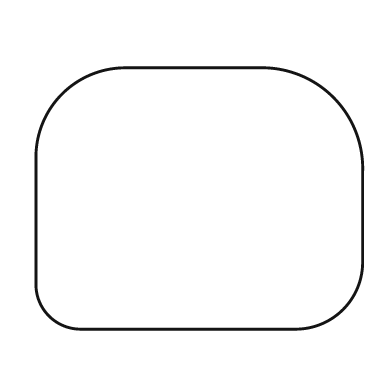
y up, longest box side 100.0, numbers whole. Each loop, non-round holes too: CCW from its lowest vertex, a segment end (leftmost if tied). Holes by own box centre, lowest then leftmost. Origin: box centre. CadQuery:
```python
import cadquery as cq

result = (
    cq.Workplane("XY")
    .moveTo(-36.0, -40.0)
    .lineTo(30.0, -40.0)
    .threePointArc((44.0, -34.0), (50.0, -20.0))
    .lineTo(50.0, 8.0)
    .threePointArc((41.0, 31.0), (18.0, 40.0))
    .lineTo(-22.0, 40.0)
    .threePointArc((-42.0, 32.0), (-50.0, 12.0))
    .lineTo(-50.0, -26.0)
    .threePointArc((-46.0, -36.0), (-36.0, -40.0))
    .close()
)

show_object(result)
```